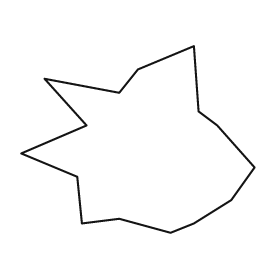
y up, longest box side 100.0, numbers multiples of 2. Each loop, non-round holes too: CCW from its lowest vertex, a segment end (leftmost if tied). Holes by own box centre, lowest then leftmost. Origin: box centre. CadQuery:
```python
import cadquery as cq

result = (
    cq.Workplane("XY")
    .moveTo(14.0, -40.0)
    .lineTo(24.0, -36.0)
    .lineTo(40.0, -26.0)
    .lineTo(50.0, -12.0)
    .lineTo(34.0, 6.0)
    .lineTo(26.0, 12.0)
    .lineTo(24.0, 40.0)
    .lineTo(0.0, 30.0)
    .lineTo(-8.0, 20.0)
    .lineTo(-40.0, 26.0)
    .lineTo(-22.0, 6.0)
    .lineTo(-50.0, -6.0)
    .lineTo(-26.0, -16.0)
    .lineTo(-24.0, -36.0)
    .lineTo(-8.0, -34.0)
    .close()
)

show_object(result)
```